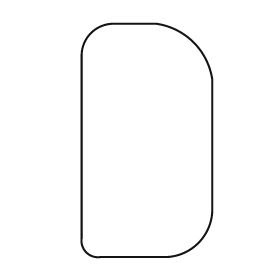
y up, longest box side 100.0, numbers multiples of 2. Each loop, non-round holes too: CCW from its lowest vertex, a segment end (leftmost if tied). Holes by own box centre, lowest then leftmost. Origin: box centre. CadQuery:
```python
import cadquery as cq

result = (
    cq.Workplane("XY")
    .moveTo(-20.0, -50.0)
    .lineTo(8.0, -50.0)
    .threePointArc((22.0, -44.0), (28.0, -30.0))
    .lineTo(28.0, 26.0)
    .threePointArc((20.0, 42.0), (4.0, 50.0))
    .lineTo(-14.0, 50.0)
    .threePointArc((-24.0, 46.0), (-28.0, 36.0))
    .lineTo(-28.0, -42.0)
    .threePointArc((-26.0, -48.0), (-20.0, -50.0))
    .close()
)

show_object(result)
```